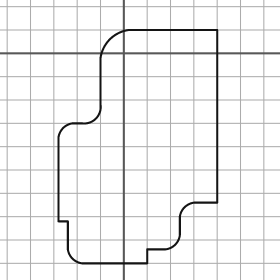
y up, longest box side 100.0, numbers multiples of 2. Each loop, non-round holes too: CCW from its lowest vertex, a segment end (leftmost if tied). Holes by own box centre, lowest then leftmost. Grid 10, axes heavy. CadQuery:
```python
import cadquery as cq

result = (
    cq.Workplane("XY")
    .moveTo(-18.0, -90.0)
    .lineTo(10.0, -90.0)
    .lineTo(10.0, -84.0)
    .lineTo(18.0, -84.0)
    .threePointArc((22.0, -82.0), (24.0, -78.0))
    .lineTo(24.0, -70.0)
    .threePointArc((26.0, -66.0), (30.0, -64.0))
    .lineTo(40.0, -64.0)
    .lineTo(40.0, 10.0)
    .lineTo(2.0, 10.0)
    .threePointArc((-6.0, 6.0), (-10.0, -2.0))
    .lineTo(-10.0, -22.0)
    .threePointArc((-12.0, -28.0), (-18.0, -30.0))
    .lineTo(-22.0, -30.0)
    .threePointArc((-26.0, -32.0), (-28.0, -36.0))
    .lineTo(-28.0, -72.0)
    .lineTo(-24.0, -72.0)
    .lineTo(-24.0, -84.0)
    .threePointArc((-22.0, -88.0), (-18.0, -90.0))
    .close()
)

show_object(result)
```